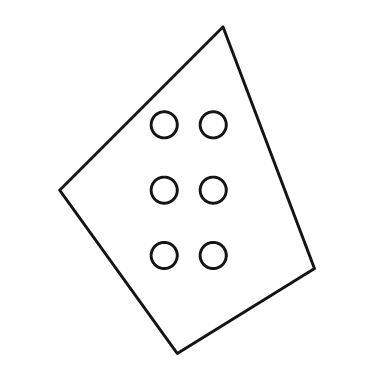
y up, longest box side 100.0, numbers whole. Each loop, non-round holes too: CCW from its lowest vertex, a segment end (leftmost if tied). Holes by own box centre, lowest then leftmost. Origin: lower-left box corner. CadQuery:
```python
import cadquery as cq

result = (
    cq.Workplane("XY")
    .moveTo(36.0, 0.0)
    .lineTo(78.0, 26.0)
    .lineTo(50.0, 100.0)
    .lineTo(0.0, 50.0)
    .close()
    .moveTo(32.0, 30.0)
    .circle(4.0)
    .moveTo(47.0, 30.0)
    .circle(4.0)
    .moveTo(32.0, 50.0)
    .circle(4.0)
    .moveTo(47.0, 50.0)
    .circle(4.0)
    .moveTo(32.0, 70.0)
    .circle(4.0)
    .moveTo(47.0, 70.0)
    .circle(4.0)
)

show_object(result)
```